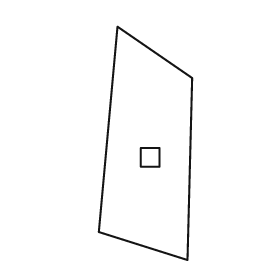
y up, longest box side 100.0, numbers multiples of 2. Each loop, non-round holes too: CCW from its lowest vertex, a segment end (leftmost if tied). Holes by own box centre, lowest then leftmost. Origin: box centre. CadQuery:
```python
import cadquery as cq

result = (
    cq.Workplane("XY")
    .moveTo(18.0, -50.0)
    .lineTo(20.0, 28.0)
    .lineTo(-12.0, 50.0)
    .lineTo(-20.0, -38.0)
    .close()
    .moveTo(-2.0, -10.0)
    .lineTo(6.0, -10.0)
    .lineTo(6.0, -2.0)
    .lineTo(-2.0, -2.0)
    .close()
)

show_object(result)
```